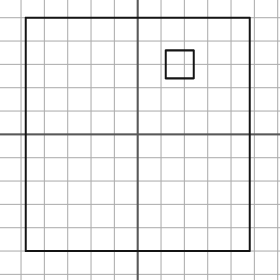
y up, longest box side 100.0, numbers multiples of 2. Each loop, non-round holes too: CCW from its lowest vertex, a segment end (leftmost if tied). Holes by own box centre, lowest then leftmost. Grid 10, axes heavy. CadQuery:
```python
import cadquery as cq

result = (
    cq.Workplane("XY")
    .moveTo(-48.0, -50.0)
    .lineTo(48.0, -50.0)
    .lineTo(48.0, 50.0)
    .lineTo(-48.0, 50.0)
    .close()
    .moveTo(12.0, 24.0)
    .lineTo(24.0, 24.0)
    .lineTo(24.0, 36.0)
    .lineTo(12.0, 36.0)
    .close()
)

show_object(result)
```